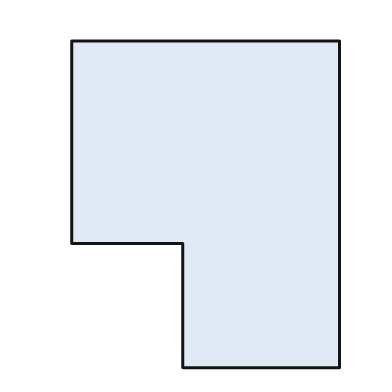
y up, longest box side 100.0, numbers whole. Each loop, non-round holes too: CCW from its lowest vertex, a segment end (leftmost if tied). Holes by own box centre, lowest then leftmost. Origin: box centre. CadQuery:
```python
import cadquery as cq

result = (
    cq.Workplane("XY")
    .moveTo(-7.0, -50.0)
    .lineTo(41.0, -50.0)
    .lineTo(41.0, 50.0)
    .lineTo(-41.0, 50.0)
    .lineTo(-41.0, -12.0)
    .lineTo(-7.0, -12.0)
    .close()
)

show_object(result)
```